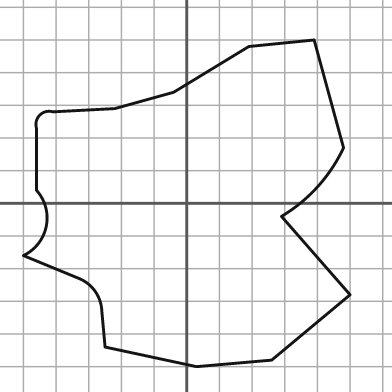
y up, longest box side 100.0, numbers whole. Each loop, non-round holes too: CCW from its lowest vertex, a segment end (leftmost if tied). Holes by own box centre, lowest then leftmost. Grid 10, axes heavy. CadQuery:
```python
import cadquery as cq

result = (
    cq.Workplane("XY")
    .moveTo(3.0, -50.0)
    .lineTo(26.0, -48.0)
    .lineTo(50.0, -28.0)
    .lineTo(29.0, -4.0)
    .threePointArc((40.0, 5.0), (48.0, 17.0))
    .lineTo(39.0, 50.0)
    .lineTo(19.0, 48.0)
    .lineTo(-4.0, 34.0)
    .lineTo(-22.0, 29.0)
    .lineTo(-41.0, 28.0)
    .threePointArc((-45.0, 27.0), (-46.0, 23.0))
    .lineTo(-46.0, 4.0)
    .threePointArc((-43.0, -7.0), (-50.0, -16.0))
    .lineTo(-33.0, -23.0)
    .threePointArc((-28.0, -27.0), (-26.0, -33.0))
    .lineTo(-25.0, -44.0)
    .close()
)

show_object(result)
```